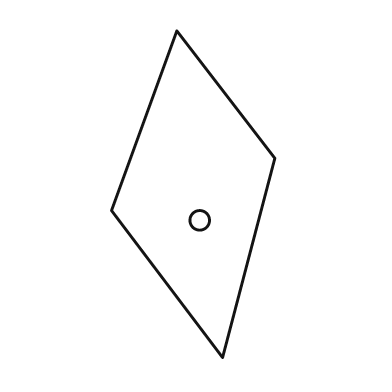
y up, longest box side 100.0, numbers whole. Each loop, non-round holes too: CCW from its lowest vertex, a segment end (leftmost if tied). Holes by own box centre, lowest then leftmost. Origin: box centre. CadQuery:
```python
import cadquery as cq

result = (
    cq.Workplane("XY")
    .moveTo(9.0, -50.0)
    .lineTo(25.0, 11.0)
    .lineTo(-5.0, 50.0)
    .lineTo(-25.0, -5.0)
    .close()
    .moveTo(2.0, -8.0)
    .circle(3.0)
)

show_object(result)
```